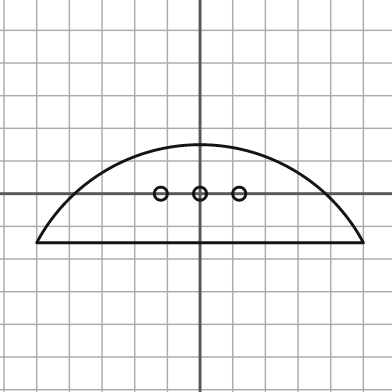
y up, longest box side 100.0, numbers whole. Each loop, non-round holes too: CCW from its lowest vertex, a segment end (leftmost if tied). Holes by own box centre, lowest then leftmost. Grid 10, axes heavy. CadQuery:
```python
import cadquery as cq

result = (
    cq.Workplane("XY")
    .moveTo(-50.0, -15.0)
    .lineTo(50.0, -15.0)
    .threePointArc((0.0, 15.0), (-50.0, -15.0))
    .close()
    .moveTo(-12.0, 0.0)
    .circle(2.0)
    .moveTo(0.0, 0.0)
    .circle(2.0)
    .moveTo(12.0, 0.0)
    .circle(2.0)
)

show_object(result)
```